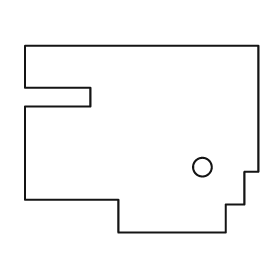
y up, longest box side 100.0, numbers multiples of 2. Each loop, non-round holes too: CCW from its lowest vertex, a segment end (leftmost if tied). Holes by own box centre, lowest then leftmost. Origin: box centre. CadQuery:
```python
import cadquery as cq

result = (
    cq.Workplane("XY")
    .moveTo(-10.0, -40.0)
    .lineTo(36.0, -40.0)
    .lineTo(36.0, -28.0)
    .lineTo(44.0, -28.0)
    .lineTo(44.0, -14.0)
    .lineTo(50.0, -14.0)
    .lineTo(50.0, 40.0)
    .lineTo(-50.0, 40.0)
    .lineTo(-50.0, 22.0)
    .lineTo(-22.0, 22.0)
    .lineTo(-22.0, 14.0)
    .lineTo(-50.0, 14.0)
    .lineTo(-50.0, -26.0)
    .lineTo(-10.0, -26.0)
    .close()
    .moveTo(26.0, -12.0)
    .circle(4.0)
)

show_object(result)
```